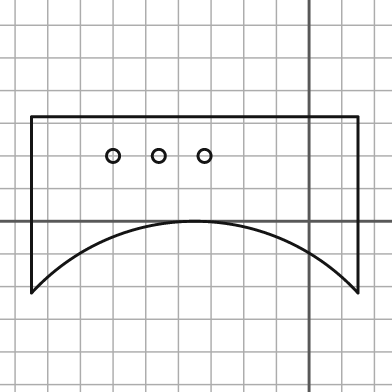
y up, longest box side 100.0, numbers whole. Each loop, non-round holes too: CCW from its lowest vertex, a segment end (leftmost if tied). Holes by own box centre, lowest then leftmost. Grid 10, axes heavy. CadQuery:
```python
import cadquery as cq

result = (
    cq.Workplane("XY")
    .moveTo(-85.0, -22.0)
    .threePointArc((-35.0, 0.0), (15.0, -22.0))
    .lineTo(15.0, 32.0)
    .lineTo(-85.0, 32.0)
    .close()
    .moveTo(-60.0, 20.0)
    .circle(2.0)
    .moveTo(-46.0, 20.0)
    .circle(2.0)
    .moveTo(-32.0, 20.0)
    .circle(2.0)
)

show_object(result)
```